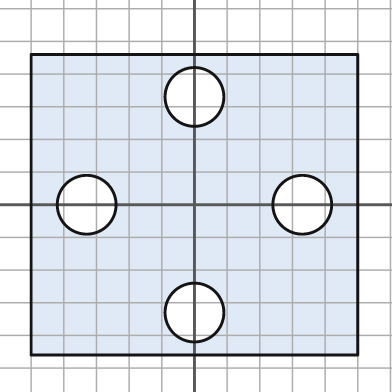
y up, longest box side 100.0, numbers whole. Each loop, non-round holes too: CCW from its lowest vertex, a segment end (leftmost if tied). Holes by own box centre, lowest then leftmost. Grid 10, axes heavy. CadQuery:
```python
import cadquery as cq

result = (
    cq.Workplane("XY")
    .moveTo(-50.0, -46.0)
    .lineTo(50.0, -46.0)
    .lineTo(50.0, 46.0)
    .lineTo(-50.0, 46.0)
    .close()
    .moveTo(0.0, -33.0)
    .circle(9.0)
    .moveTo(-33.0, 0.0)
    .circle(9.0)
    .moveTo(33.0, 0.0)
    .circle(9.0)
    .moveTo(0.0, 33.0)
    .circle(9.0)
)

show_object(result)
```